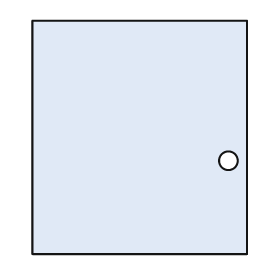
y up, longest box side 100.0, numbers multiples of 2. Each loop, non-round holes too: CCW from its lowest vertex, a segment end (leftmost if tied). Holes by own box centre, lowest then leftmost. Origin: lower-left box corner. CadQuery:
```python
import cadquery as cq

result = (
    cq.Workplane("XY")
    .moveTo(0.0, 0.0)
    .lineTo(92.0, 0.0)
    .lineTo(92.0, 100.0)
    .lineTo(0.0, 100.0)
    .close()
    .moveTo(84.0, 40.0)
    .circle(4.0)
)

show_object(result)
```